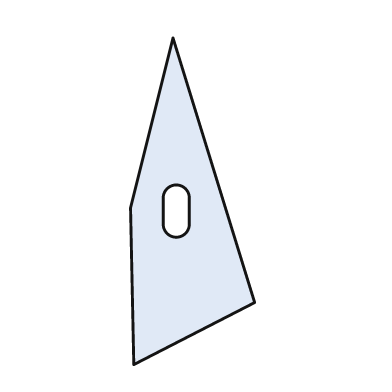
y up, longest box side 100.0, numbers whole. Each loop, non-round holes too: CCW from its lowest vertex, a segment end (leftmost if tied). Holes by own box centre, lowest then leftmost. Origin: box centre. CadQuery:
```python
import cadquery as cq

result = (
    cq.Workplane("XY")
    .moveTo(-18.0, -50.0)
    .lineTo(19.0, -31.0)
    .lineTo(-6.0, 50.0)
    .lineTo(-19.0, -2.0)
    .close()
    .moveTo(-9.0, -7.0)
    .threePointArc((-5.0, -11.0), (-1.0, -7.0))
    .lineTo(-1.0, 1.0)
    .threePointArc((-5.0, 5.0), (-9.0, 1.0))
    .close()
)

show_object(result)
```